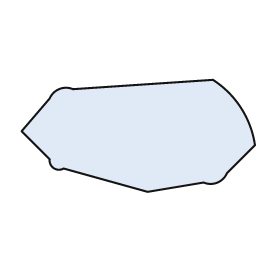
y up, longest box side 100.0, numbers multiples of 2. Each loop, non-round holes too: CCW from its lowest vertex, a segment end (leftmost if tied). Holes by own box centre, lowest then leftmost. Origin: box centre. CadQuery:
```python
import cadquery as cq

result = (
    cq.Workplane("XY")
    .moveTo(4.0, -24.0)
    .lineTo(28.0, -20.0)
    .threePointArc((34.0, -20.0), (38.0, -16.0))
    .lineTo(50.0, -4.0)
    .threePointArc((44.0, 12.0), (32.0, 24.0))
    .lineTo(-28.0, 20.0)
    .threePointArc((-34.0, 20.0), (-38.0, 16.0))
    .lineTo(-50.0, 2.0)
    .lineTo(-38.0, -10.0)
    .threePointArc((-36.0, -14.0), (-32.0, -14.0))
    .close()
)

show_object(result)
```